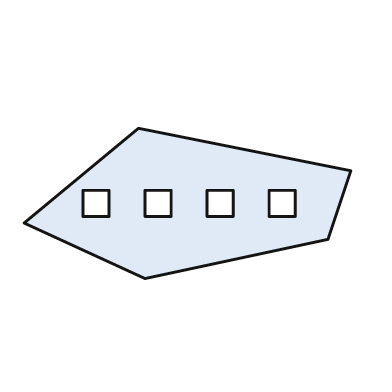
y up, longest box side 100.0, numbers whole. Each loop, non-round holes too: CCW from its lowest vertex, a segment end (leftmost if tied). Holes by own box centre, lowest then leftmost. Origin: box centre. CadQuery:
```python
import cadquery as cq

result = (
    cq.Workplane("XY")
    .moveTo(-13.0, -23.0)
    .lineTo(43.0, -11.0)
    .lineTo(50.0, 10.0)
    .lineTo(-15.0, 23.0)
    .lineTo(-50.0, -6.0)
    .close()
    .moveTo(-32.0, -4.0)
    .lineTo(-24.0, -4.0)
    .lineTo(-24.0, 4.0)
    .lineTo(-32.0, 4.0)
    .close()
    .moveTo(-13.0, -4.0)
    .lineTo(-5.0, -4.0)
    .lineTo(-5.0, 4.0)
    .lineTo(-13.0, 4.0)
    .close()
    .moveTo(6.0, -4.0)
    .lineTo(14.0, -4.0)
    .lineTo(14.0, 4.0)
    .lineTo(6.0, 4.0)
    .close()
    .moveTo(25.0, -4.0)
    .lineTo(33.0, -4.0)
    .lineTo(33.0, 4.0)
    .lineTo(25.0, 4.0)
    .close()
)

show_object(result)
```